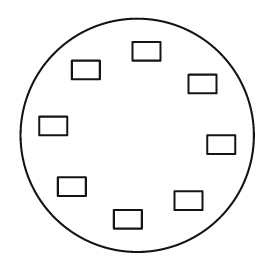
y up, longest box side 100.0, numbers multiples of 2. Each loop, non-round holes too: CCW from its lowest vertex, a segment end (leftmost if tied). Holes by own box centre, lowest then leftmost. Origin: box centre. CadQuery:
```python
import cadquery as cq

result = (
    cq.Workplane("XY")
    .moveTo(0.0, 0.0)
    .circle(50.0)
    .moveTo(-10.0, -40.0)
    .lineTo(2.0, -40.0)
    .lineTo(2.0, -32.0)
    .lineTo(-10.0, -32.0)
    .close()
    .moveTo(16.0, -32.0)
    .lineTo(28.0, -32.0)
    .lineTo(28.0, -24.0)
    .lineTo(16.0, -24.0)
    .close()
    .moveTo(-34.0, -26.0)
    .lineTo(-22.0, -26.0)
    .lineTo(-22.0, -18.0)
    .lineTo(-34.0, -18.0)
    .close()
    .moveTo(30.0, -8.0)
    .lineTo(42.0, -8.0)
    .lineTo(42.0, 0.0)
    .lineTo(30.0, 0.0)
    .close()
    .moveTo(-42.0, 0.0)
    .lineTo(-30.0, 0.0)
    .lineTo(-30.0, 8.0)
    .lineTo(-42.0, 8.0)
    .close()
    .moveTo(22.0, 18.0)
    .lineTo(34.0, 18.0)
    .lineTo(34.0, 26.0)
    .lineTo(22.0, 26.0)
    .close()
    .moveTo(-28.0, 24.0)
    .lineTo(-16.0, 24.0)
    .lineTo(-16.0, 32.0)
    .lineTo(-28.0, 32.0)
    .close()
    .moveTo(-2.0, 32.0)
    .lineTo(10.0, 32.0)
    .lineTo(10.0, 40.0)
    .lineTo(-2.0, 40.0)
    .close()
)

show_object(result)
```